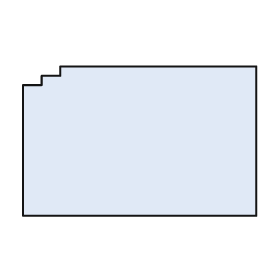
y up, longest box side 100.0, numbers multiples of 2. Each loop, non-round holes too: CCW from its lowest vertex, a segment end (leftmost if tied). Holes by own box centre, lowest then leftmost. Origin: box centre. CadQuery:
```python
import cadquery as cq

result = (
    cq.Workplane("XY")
    .moveTo(-50.0, -32.0)
    .lineTo(50.0, -32.0)
    .lineTo(50.0, 32.0)
    .lineTo(-34.0, 32.0)
    .lineTo(-34.0, 28.0)
    .lineTo(-42.0, 28.0)
    .lineTo(-42.0, 24.0)
    .lineTo(-50.0, 24.0)
    .close()
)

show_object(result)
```